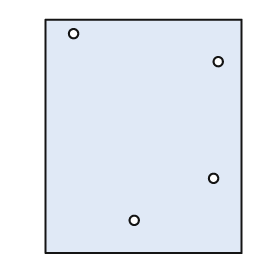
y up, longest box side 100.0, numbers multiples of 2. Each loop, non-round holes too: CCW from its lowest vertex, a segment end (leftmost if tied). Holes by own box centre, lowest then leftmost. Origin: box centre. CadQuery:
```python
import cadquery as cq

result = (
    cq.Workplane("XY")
    .moveTo(-42.0, -50.0)
    .lineTo(42.0, -50.0)
    .lineTo(42.0, 50.0)
    .lineTo(-42.0, 50.0)
    .close()
    .moveTo(-4.0, -36.0)
    .circle(2.0)
    .moveTo(30.0, -18.0)
    .circle(2.0)
    .moveTo(32.0, 32.0)
    .circle(2.0)
    .moveTo(-30.0, 44.0)
    .circle(2.0)
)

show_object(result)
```